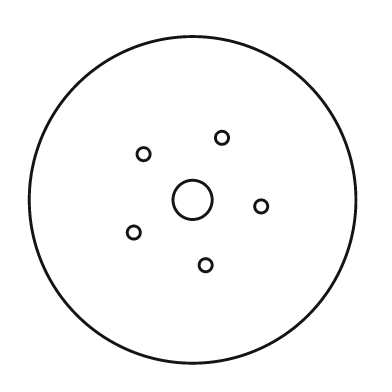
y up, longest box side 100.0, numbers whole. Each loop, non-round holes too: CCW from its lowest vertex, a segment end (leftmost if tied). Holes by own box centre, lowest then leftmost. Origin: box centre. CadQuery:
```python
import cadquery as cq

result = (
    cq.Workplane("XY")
    .moveTo(0.0, 0.0)
    .circle(50.0)
    .moveTo(4.0, -20.0)
    .circle(2.0)
    .moveTo(-18.0, -10.0)
    .circle(2.0)
    .moveTo(21.0, -2.0)
    .circle(2.0)
    .moveTo(0.0, 0.0)
    .circle(6.0)
    .moveTo(-15.0, 14.0)
    .circle(2.0)
    .moveTo(9.0, 19.0)
    .circle(2.0)
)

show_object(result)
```